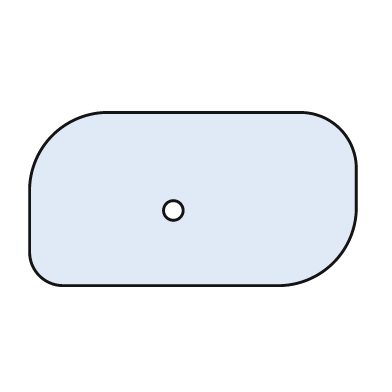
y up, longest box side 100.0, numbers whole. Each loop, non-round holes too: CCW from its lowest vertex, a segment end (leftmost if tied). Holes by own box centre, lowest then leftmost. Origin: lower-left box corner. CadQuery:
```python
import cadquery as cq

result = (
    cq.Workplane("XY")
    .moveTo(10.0, 0.0)
    .lineTo(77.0, 0.0)
    .threePointArc((93.0, 7.0), (100.0, 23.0))
    .lineTo(100.0, 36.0)
    .threePointArc((95.0, 48.0), (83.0, 53.0))
    .lineTo(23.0, 53.0)
    .threePointArc((7.0, 46.0), (0.0, 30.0))
    .lineTo(0.0, 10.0)
    .threePointArc((3.0, 3.0), (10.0, 0.0))
    .close()
    .moveTo(44.0, 23.0)
    .circle(3.0)
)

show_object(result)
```